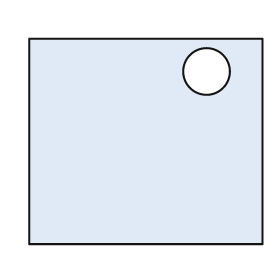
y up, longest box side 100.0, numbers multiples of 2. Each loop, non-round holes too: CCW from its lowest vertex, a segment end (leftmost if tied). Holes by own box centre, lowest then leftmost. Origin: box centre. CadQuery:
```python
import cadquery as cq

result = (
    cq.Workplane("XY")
    .moveTo(-50.0, -44.0)
    .lineTo(50.0, -44.0)
    .lineTo(50.0, 44.0)
    .lineTo(-50.0, 44.0)
    .close()
    .moveTo(26.0, 30.0)
    .circle(10.0)
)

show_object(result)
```